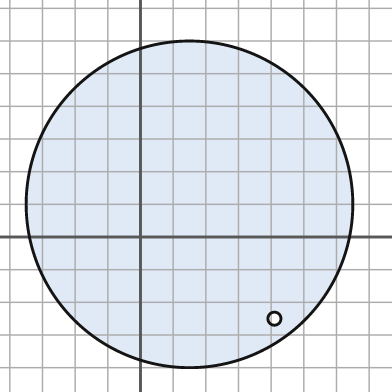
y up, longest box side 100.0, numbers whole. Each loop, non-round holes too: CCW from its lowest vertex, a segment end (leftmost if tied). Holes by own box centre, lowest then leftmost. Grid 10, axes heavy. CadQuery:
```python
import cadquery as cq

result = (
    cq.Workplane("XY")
    .moveTo(15.0, 10.0)
    .circle(50.0)
    .moveTo(41.0, -25.0)
    .circle(2.0)
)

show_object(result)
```